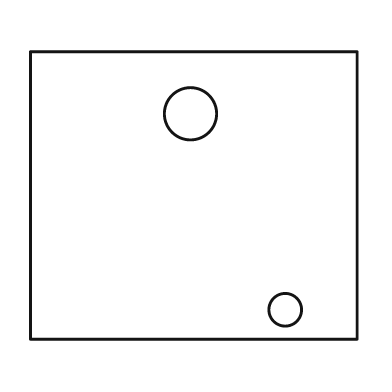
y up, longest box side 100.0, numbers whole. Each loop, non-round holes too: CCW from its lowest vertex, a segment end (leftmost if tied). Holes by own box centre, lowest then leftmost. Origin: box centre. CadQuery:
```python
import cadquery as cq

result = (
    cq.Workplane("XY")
    .moveTo(-50.0, -44.0)
    .lineTo(50.0, -44.0)
    .lineTo(50.0, 44.0)
    .lineTo(-50.0, 44.0)
    .close()
    .moveTo(28.0, -35.0)
    .circle(5.0)
    .moveTo(-1.0, 25.0)
    .circle(8.0)
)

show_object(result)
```